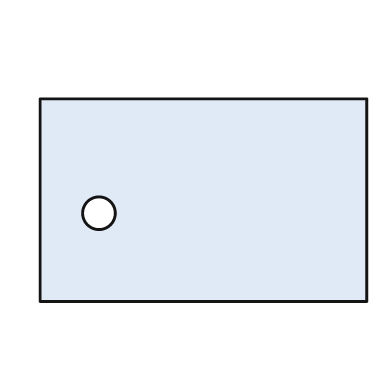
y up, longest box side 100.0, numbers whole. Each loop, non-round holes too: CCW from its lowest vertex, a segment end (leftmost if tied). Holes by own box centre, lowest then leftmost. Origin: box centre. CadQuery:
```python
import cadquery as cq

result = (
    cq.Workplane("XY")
    .moveTo(-50.0, -31.0)
    .lineTo(50.0, -31.0)
    .lineTo(50.0, 31.0)
    .lineTo(-50.0, 31.0)
    .close()
    .moveTo(-32.0, -4.0)
    .circle(5.0)
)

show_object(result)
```